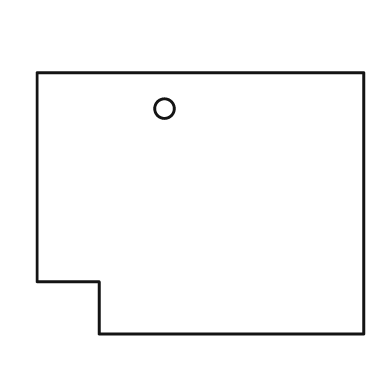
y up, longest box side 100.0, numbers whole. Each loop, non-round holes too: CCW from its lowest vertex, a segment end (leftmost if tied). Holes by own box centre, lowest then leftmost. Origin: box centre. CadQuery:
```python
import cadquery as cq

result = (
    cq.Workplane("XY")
    .moveTo(-31.0, -40.0)
    .lineTo(50.0, -40.0)
    .lineTo(50.0, 40.0)
    .lineTo(-50.0, 40.0)
    .lineTo(-50.0, -24.0)
    .lineTo(-31.0, -24.0)
    .close()
    .moveTo(-11.0, 29.0)
    .circle(3.0)
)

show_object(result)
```